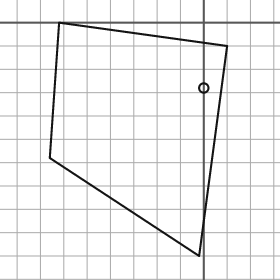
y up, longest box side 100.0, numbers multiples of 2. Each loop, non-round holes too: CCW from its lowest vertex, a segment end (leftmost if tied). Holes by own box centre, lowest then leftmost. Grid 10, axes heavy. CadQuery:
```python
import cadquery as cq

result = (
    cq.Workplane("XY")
    .moveTo(-2.0, -100.0)
    .lineTo(10.0, -10.0)
    .lineTo(-62.0, 0.0)
    .lineTo(-66.0, -58.0)
    .close()
    .moveTo(0.0, -28.0)
    .circle(2.0)
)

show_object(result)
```